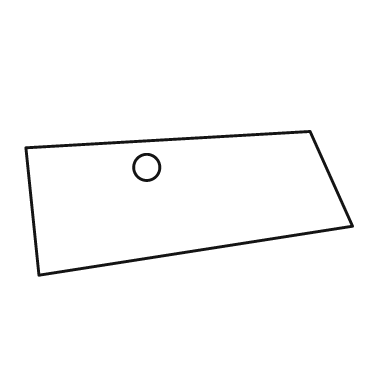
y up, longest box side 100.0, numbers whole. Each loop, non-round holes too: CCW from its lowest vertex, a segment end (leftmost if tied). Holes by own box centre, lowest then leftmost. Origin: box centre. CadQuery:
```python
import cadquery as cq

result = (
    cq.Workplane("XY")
    .moveTo(-46.0, -22.0)
    .lineTo(50.0, -7.0)
    .lineTo(37.0, 22.0)
    .lineTo(-50.0, 17.0)
    .close()
    .moveTo(-13.0, 11.0)
    .circle(4.0)
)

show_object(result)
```